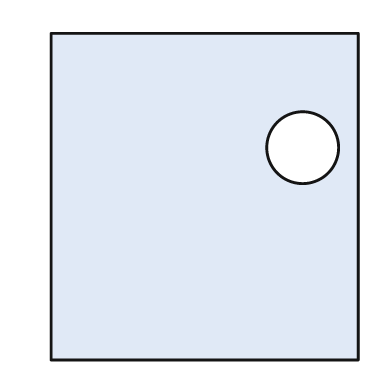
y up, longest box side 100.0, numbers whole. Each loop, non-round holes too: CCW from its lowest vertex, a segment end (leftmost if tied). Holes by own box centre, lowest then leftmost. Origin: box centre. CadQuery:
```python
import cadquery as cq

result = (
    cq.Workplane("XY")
    .moveTo(-47.0, -50.0)
    .lineTo(47.0, -50.0)
    .lineTo(47.0, 50.0)
    .lineTo(-47.0, 50.0)
    .close()
    .moveTo(30.0, 15.0)
    .circle(11.0)
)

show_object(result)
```